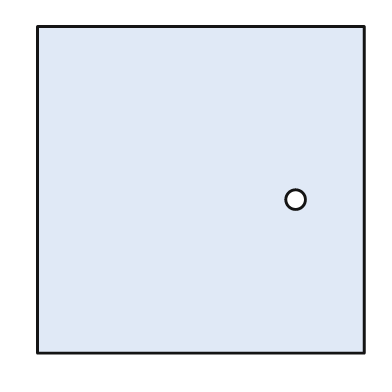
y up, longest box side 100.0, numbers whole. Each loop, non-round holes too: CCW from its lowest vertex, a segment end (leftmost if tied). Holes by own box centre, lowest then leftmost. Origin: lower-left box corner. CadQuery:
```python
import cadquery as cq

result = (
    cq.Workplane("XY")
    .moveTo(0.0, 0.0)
    .lineTo(100.0, 0.0)
    .lineTo(100.0, 100.0)
    .lineTo(0.0, 100.0)
    .close()
    .moveTo(79.0, 47.0)
    .circle(3.0)
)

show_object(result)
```